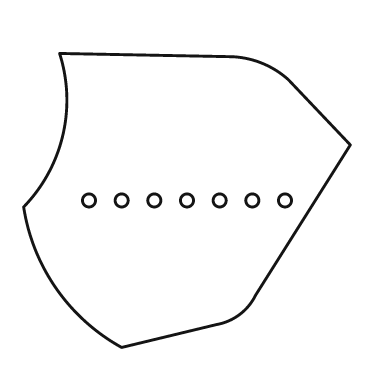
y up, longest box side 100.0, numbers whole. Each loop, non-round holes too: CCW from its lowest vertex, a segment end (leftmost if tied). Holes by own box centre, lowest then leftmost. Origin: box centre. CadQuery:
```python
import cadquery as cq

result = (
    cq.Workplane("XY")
    .moveTo(-20.0, -45.0)
    .lineTo(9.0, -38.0)
    .threePointArc((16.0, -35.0), (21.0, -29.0))
    .lineTo(50.0, 17.0)
    .lineTo(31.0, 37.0)
    .threePointArc((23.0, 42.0), (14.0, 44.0))
    .lineTo(-39.0, 45.0)
    .threePointArc((-38.0, 20.0), (-50.0, -2.0))
    .threePointArc((-40.0, -27.0), (-20.0, -45.0))
    .close()
    .moveTo(-30.0, 0.0)
    .circle(2.0)
    .moveTo(-20.0, 0.0)
    .circle(2.0)
    .moveTo(-10.0, 0.0)
    .circle(2.0)
    .moveTo(0.0, 0.0)
    .circle(2.0)
    .moveTo(10.0, 0.0)
    .circle(2.0)
    .moveTo(20.0, 0.0)
    .circle(2.0)
    .moveTo(30.0, 0.0)
    .circle(2.0)
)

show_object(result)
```